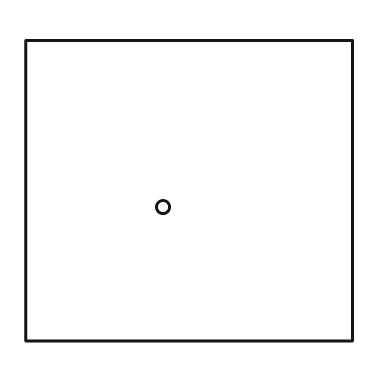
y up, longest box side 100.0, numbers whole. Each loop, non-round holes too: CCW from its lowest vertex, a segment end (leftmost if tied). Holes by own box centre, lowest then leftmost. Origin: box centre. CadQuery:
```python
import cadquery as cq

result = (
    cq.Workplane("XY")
    .moveTo(-50.0, -46.0)
    .lineTo(50.0, -46.0)
    .lineTo(50.0, 46.0)
    .lineTo(-50.0, 46.0)
    .close()
    .moveTo(-8.0, -5.0)
    .circle(2.0)
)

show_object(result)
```